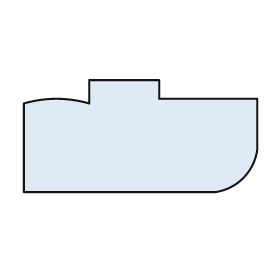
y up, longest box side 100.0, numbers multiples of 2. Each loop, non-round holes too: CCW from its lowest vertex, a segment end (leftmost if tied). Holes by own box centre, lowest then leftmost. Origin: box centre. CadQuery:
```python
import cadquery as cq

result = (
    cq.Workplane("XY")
    .moveTo(-50.0, -24.0)
    .lineTo(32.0, -24.0)
    .threePointArc((44.0, -18.0), (50.0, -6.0))
    .lineTo(50.0, 16.0)
    .lineTo(8.0, 16.0)
    .lineTo(8.0, 24.0)
    .lineTo(-22.0, 24.0)
    .lineTo(-22.0, 14.0)
    .threePointArc((-36.0, 16.0), (-50.0, 14.0))
    .close()
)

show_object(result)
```